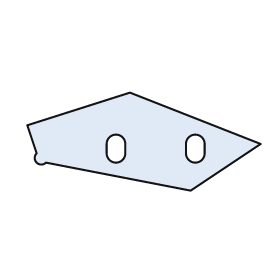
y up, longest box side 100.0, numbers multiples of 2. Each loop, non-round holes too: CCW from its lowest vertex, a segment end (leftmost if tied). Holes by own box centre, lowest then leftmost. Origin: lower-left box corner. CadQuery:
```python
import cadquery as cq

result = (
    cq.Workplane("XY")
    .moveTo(70.0, 0.0)
    .lineTo(100.0, 20.0)
    .lineTo(44.0, 42.0)
    .lineTo(0.0, 28.0)
    .lineTo(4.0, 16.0)
    .threePointArc((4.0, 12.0), (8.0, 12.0))
    .close()
    .moveTo(34.0, 16.0)
    .threePointArc((38.0, 12.0), (42.0, 16.0))
    .lineTo(42.0, 20.0)
    .threePointArc((38.0, 24.0), (34.0, 20.0))
    .close()
    .moveTo(68.0, 16.0)
    .threePointArc((72.0, 12.0), (76.0, 16.0))
    .lineTo(76.0, 20.0)
    .threePointArc((72.0, 24.0), (68.0, 20.0))
    .close()
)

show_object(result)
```